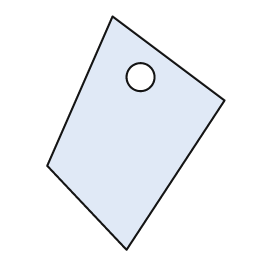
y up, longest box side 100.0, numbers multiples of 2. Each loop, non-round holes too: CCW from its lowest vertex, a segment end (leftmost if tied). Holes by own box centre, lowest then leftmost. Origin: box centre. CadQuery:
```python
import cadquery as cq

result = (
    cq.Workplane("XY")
    .moveTo(-4.0, -50.0)
    .lineTo(38.0, 14.0)
    .lineTo(-10.0, 50.0)
    .lineTo(-38.0, -14.0)
    .close()
    .moveTo(2.0, 24.0)
    .circle(6.0)
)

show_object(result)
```